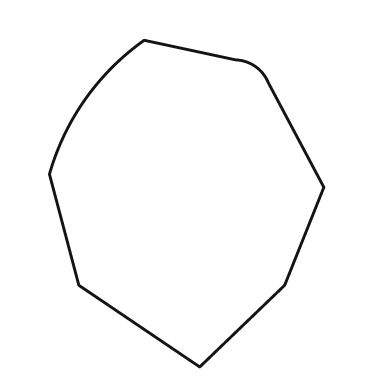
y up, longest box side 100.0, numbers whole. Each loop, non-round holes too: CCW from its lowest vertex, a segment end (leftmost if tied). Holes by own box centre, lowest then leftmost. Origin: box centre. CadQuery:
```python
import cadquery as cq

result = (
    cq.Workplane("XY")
    .moveTo(4.0, -50.0)
    .lineTo(30.0, -25.0)
    .lineTo(42.0, 5.0)
    .lineTo(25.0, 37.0)
    .threePointArc((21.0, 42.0), (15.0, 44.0))
    .lineTo(-13.0, 50.0)
    .threePointArc((-31.0, 32.0), (-42.0, 9.0))
    .lineTo(-33.0, -25.0)
    .close()
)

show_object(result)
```